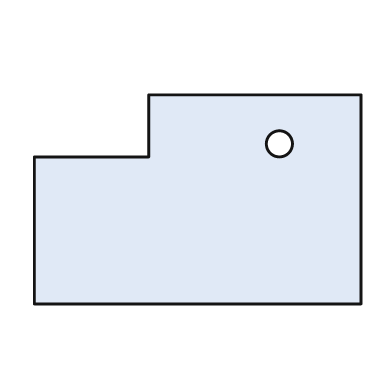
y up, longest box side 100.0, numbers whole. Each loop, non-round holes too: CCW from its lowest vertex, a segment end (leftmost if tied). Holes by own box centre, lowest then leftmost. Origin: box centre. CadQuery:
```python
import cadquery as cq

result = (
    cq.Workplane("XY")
    .moveTo(-50.0, -32.0)
    .lineTo(50.0, -32.0)
    .lineTo(50.0, 32.0)
    .lineTo(-15.0, 32.0)
    .lineTo(-15.0, 13.0)
    .lineTo(-50.0, 13.0)
    .close()
    .moveTo(25.0, 17.0)
    .circle(4.0)
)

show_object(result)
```